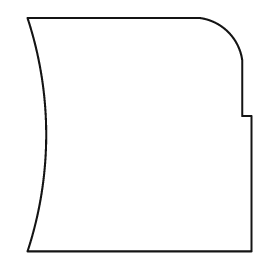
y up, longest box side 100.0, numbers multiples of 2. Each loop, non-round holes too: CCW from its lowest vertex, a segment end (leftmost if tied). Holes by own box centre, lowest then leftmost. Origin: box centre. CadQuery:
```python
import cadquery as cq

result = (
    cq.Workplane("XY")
    .moveTo(-48.0, -50.0)
    .lineTo(48.0, -50.0)
    .lineTo(48.0, 8.0)
    .lineTo(44.0, 8.0)
    .lineTo(44.0, 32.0)
    .threePointArc((38.0, 44.0), (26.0, 50.0))
    .lineTo(-48.0, 50.0)
    .threePointArc((-40.0, 0.0), (-48.0, -50.0))
    .close()
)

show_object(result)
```